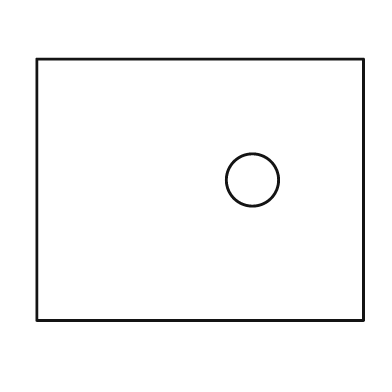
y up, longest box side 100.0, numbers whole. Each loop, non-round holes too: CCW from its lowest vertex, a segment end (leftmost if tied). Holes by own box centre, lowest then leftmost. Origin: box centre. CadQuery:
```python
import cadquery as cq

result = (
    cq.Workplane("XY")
    .moveTo(-50.0, -40.0)
    .lineTo(50.0, -40.0)
    .lineTo(50.0, 40.0)
    .lineTo(-50.0, 40.0)
    .close()
    .moveTo(16.0, 3.0)
    .circle(8.0)
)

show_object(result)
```